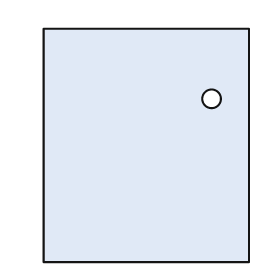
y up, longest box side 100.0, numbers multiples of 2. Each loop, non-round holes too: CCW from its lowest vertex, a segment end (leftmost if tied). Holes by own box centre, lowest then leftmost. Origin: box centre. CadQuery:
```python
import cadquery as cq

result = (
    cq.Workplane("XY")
    .moveTo(-44.0, -50.0)
    .lineTo(44.0, -50.0)
    .lineTo(44.0, 50.0)
    .lineTo(-44.0, 50.0)
    .close()
    .moveTo(28.0, 20.0)
    .circle(4.0)
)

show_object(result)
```